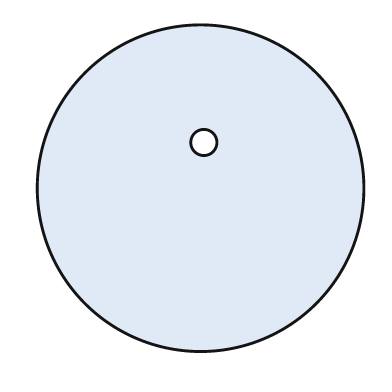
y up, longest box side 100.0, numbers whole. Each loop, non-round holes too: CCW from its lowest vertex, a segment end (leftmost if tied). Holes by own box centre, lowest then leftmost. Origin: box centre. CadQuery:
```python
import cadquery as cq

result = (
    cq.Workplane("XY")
    .moveTo(0.0, 0.0)
    .circle(50.0)
    .moveTo(1.0, 14.0)
    .circle(4.0)
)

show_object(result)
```